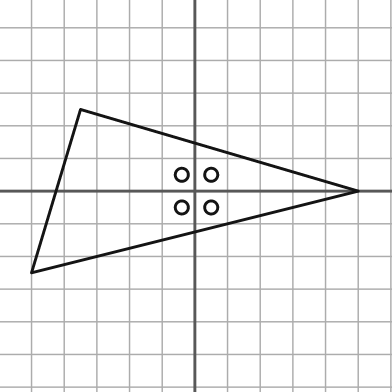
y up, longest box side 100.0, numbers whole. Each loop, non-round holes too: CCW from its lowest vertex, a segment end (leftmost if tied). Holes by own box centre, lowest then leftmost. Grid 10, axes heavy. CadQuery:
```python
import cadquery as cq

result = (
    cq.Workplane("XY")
    .moveTo(-50.0, -25.0)
    .lineTo(50.0, 0.0)
    .lineTo(-35.0, 25.0)
    .close()
    .moveTo(-4.0, -5.0)
    .circle(2.0)
    .moveTo(5.0, -5.0)
    .circle(2.0)
    .moveTo(-4.0, 5.0)
    .circle(2.0)
    .moveTo(5.0, 5.0)
    .circle(2.0)
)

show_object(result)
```